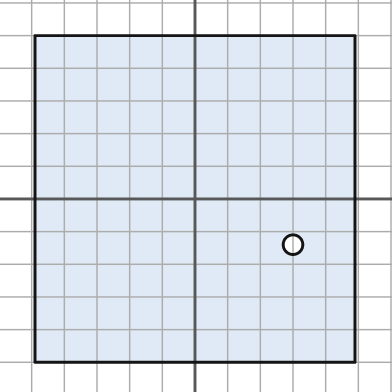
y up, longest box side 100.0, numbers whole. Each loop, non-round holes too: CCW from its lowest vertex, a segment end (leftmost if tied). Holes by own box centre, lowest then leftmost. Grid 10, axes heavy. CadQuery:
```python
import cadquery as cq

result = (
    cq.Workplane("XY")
    .moveTo(-49.0, -50.0)
    .lineTo(49.0, -50.0)
    .lineTo(49.0, 50.0)
    .lineTo(-49.0, 50.0)
    .close()
    .moveTo(30.0, -14.0)
    .circle(3.0)
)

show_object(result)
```